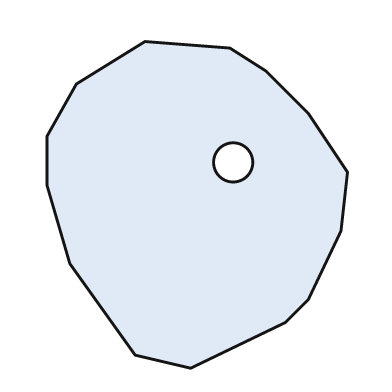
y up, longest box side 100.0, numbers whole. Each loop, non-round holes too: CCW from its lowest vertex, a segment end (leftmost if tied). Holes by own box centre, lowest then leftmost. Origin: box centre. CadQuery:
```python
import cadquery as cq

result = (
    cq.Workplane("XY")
    .moveTo(-2.0, -50.0)
    .lineTo(27.0, -36.0)
    .lineTo(34.0, -29.0)
    .lineTo(44.0, -8.0)
    .lineTo(46.0, 10.0)
    .lineTo(34.0, 28.0)
    .lineTo(21.0, 41.0)
    .lineTo(10.0, 48.0)
    .lineTo(-16.0, 50.0)
    .lineTo(-37.0, 37.0)
    .lineTo(-46.0, 21.0)
    .lineTo(-46.0, 6.0)
    .lineTo(-39.0, -18.0)
    .lineTo(-19.0, -46.0)
    .close()
    .moveTo(11.0, 13.0)
    .circle(6.0)
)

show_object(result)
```